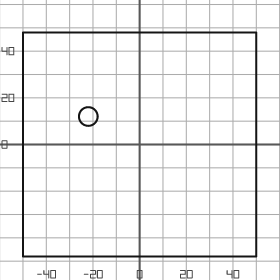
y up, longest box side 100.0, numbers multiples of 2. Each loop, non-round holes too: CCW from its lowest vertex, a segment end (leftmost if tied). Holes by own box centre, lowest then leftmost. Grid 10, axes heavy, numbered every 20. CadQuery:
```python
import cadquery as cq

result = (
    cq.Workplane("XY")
    .moveTo(-50.0, -48.0)
    .lineTo(50.0, -48.0)
    .lineTo(50.0, 48.0)
    .lineTo(-50.0, 48.0)
    .close()
    .moveTo(-22.0, 12.0)
    .circle(4.0)
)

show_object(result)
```